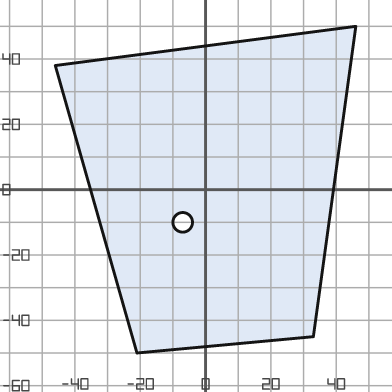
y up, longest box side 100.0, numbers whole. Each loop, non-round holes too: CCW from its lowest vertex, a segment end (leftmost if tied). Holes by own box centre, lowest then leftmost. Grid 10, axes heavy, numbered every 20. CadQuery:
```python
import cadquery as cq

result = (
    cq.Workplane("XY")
    .moveTo(-21.0, -50.0)
    .lineTo(33.0, -45.0)
    .lineTo(46.0, 50.0)
    .lineTo(-46.0, 38.0)
    .close()
    .moveTo(-7.0, -10.0)
    .circle(3.0)
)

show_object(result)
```